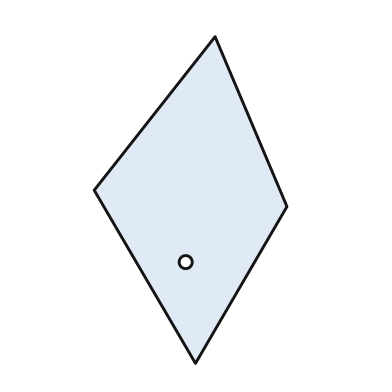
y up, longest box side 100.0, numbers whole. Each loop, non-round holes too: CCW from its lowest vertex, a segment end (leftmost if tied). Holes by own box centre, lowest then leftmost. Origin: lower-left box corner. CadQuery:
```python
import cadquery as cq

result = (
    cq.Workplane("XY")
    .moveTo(31.0, 0.0)
    .lineTo(59.0, 48.0)
    .lineTo(37.0, 100.0)
    .lineTo(0.0, 53.0)
    .close()
    .moveTo(28.0, 31.0)
    .circle(2.0)
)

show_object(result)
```